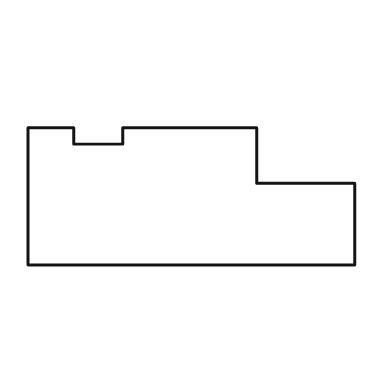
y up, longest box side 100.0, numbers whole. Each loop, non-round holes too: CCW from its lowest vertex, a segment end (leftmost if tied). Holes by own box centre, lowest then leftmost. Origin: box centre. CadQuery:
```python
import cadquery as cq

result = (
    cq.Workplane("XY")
    .moveTo(-50.0, -21.0)
    .lineTo(50.0, -21.0)
    .lineTo(50.0, 4.0)
    .lineTo(20.0, 4.0)
    .lineTo(20.0, 21.0)
    .lineTo(-21.0, 21.0)
    .lineTo(-21.0, 16.0)
    .lineTo(-36.0, 16.0)
    .lineTo(-36.0, 21.0)
    .lineTo(-50.0, 21.0)
    .close()
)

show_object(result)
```